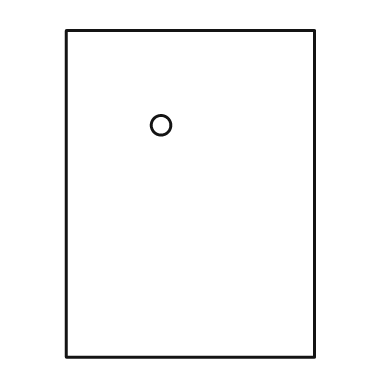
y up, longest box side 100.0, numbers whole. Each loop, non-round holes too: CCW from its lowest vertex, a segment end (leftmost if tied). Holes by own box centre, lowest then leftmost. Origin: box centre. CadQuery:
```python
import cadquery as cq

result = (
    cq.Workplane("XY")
    .moveTo(-38.0, -50.0)
    .lineTo(38.0, -50.0)
    .lineTo(38.0, 50.0)
    .lineTo(-38.0, 50.0)
    .close()
    .moveTo(-9.0, 21.0)
    .circle(3.0)
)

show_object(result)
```